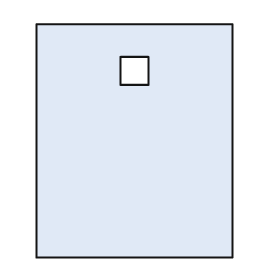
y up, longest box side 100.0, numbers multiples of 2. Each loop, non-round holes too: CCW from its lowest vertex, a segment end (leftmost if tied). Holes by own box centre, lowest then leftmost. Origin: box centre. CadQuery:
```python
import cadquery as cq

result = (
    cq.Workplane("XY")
    .moveTo(-42.0, -50.0)
    .lineTo(42.0, -50.0)
    .lineTo(42.0, 50.0)
    .lineTo(-42.0, 50.0)
    .close()
    .moveTo(-6.0, 24.0)
    .lineTo(6.0, 24.0)
    .lineTo(6.0, 36.0)
    .lineTo(-6.0, 36.0)
    .close()
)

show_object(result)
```